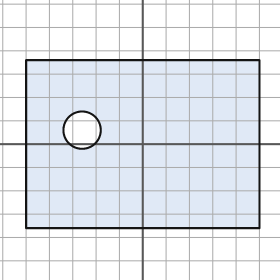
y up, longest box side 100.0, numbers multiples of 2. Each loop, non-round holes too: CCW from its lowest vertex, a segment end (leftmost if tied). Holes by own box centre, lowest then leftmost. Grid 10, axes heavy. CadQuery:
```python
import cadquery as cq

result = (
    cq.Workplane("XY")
    .moveTo(-50.0, -36.0)
    .lineTo(50.0, -36.0)
    .lineTo(50.0, 36.0)
    .lineTo(-50.0, 36.0)
    .close()
    .moveTo(-26.0, 6.0)
    .circle(8.0)
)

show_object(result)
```